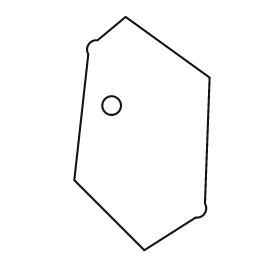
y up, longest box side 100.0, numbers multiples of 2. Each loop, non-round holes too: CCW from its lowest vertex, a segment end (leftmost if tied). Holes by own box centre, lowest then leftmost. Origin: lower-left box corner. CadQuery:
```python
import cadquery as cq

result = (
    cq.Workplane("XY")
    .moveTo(30.0, 0.0)
    .lineTo(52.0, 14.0)
    .threePointArc((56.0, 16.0), (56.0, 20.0))
    .lineTo(58.0, 74.0)
    .lineTo(22.0, 100.0)
    .lineTo(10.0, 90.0)
    .threePointArc((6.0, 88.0), (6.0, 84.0))
    .lineTo(0.0, 30.0)
    .close()
    .moveTo(16.0, 62.0)
    .circle(4.0)
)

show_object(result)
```